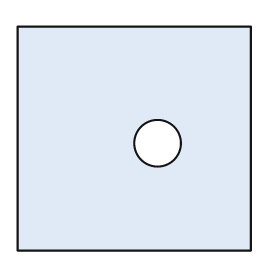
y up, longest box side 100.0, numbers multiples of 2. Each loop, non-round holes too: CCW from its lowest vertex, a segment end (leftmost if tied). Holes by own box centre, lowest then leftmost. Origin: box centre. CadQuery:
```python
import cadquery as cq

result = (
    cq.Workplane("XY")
    .moveTo(-50.0, -48.0)
    .lineTo(50.0, -48.0)
    .lineTo(50.0, 48.0)
    .lineTo(-50.0, 48.0)
    .close()
    .moveTo(10.0, -2.0)
    .circle(10.0)
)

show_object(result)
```